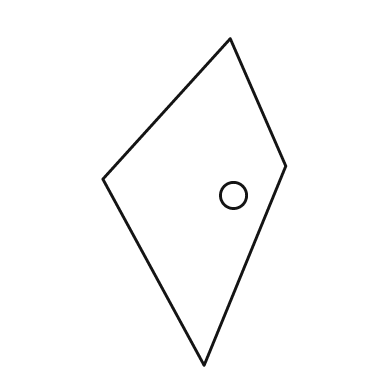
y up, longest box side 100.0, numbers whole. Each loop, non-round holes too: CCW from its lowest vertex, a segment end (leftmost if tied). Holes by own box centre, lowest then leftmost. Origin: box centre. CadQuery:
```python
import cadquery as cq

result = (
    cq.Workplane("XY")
    .moveTo(3.0, -50.0)
    .lineTo(28.0, 11.0)
    .lineTo(11.0, 50.0)
    .lineTo(-28.0, 7.0)
    .close()
    .moveTo(12.0, 2.0)
    .circle(4.0)
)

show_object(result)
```